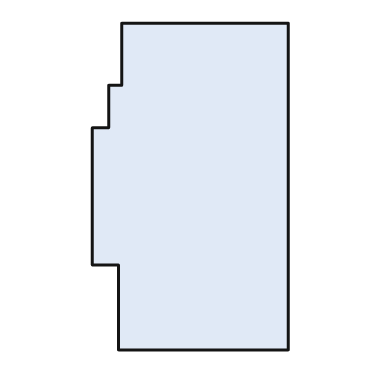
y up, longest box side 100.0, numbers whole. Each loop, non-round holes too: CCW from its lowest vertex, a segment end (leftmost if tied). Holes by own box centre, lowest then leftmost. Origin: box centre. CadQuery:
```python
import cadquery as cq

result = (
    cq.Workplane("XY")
    .moveTo(-22.0, -50.0)
    .lineTo(30.0, -50.0)
    .lineTo(30.0, 50.0)
    .lineTo(-21.0, 50.0)
    .lineTo(-21.0, 31.0)
    .lineTo(-25.0, 31.0)
    .lineTo(-25.0, 18.0)
    .lineTo(-30.0, 18.0)
    .lineTo(-30.0, -24.0)
    .lineTo(-22.0, -24.0)
    .close()
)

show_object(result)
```